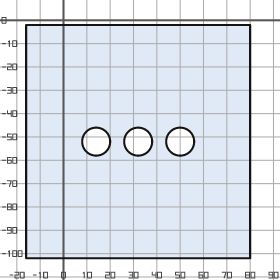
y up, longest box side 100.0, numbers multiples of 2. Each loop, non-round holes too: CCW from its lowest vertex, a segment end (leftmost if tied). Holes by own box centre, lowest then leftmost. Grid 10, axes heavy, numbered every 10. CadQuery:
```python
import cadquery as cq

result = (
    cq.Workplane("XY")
    .moveTo(-16.0, -102.0)
    .lineTo(80.0, -102.0)
    .lineTo(80.0, -2.0)
    .lineTo(-16.0, -2.0)
    .close()
    .moveTo(14.0, -52.0)
    .circle(6.0)
    .moveTo(32.0, -52.0)
    .circle(6.0)
    .moveTo(50.0, -52.0)
    .circle(6.0)
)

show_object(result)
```